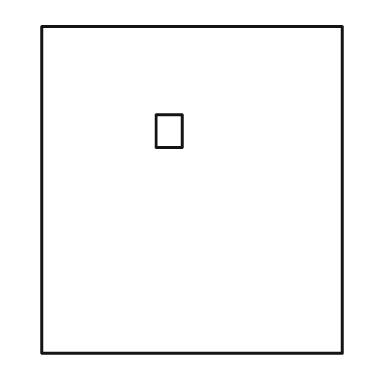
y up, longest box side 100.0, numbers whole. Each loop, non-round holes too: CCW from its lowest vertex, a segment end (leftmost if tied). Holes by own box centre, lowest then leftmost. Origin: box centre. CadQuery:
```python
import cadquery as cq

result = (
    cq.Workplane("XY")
    .moveTo(-46.0, -50.0)
    .lineTo(46.0, -50.0)
    .lineTo(46.0, 50.0)
    .lineTo(-46.0, 50.0)
    .close()
    .moveTo(-11.0, 13.0)
    .lineTo(-3.0, 13.0)
    .lineTo(-3.0, 23.0)
    .lineTo(-11.0, 23.0)
    .close()
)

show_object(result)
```